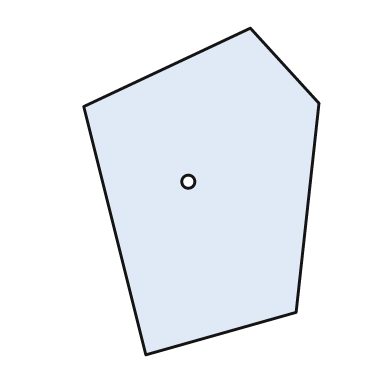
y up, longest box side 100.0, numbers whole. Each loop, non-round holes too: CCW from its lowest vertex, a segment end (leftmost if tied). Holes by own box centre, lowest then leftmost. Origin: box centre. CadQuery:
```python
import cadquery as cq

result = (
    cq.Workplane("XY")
    .moveTo(-17.0, -50.0)
    .lineTo(29.0, -37.0)
    .lineTo(36.0, 27.0)
    .lineTo(15.0, 50.0)
    .lineTo(-36.0, 26.0)
    .close()
    .moveTo(-4.0, 3.0)
    .circle(2.0)
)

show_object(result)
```